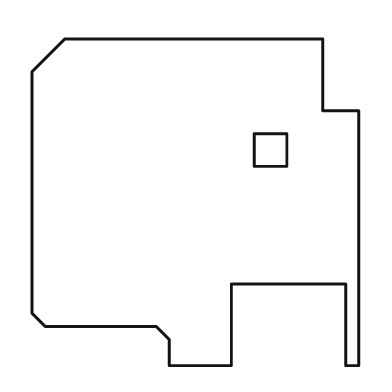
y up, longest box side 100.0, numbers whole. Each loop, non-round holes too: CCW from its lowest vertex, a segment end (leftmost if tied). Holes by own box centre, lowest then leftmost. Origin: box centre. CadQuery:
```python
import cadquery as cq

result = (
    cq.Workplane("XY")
    .moveTo(-8.0, -50.0)
    .lineTo(11.0, -50.0)
    .lineTo(11.0, -25.0)
    .lineTo(46.0, -25.0)
    .lineTo(46.0, -50.0)
    .lineTo(50.0, -50.0)
    .lineTo(50.0, 28.0)
    .lineTo(39.0, 28.0)
    .lineTo(39.0, 50.0)
    .lineTo(-40.0, 50.0)
    .lineTo(-50.0, 40.0)
    .lineTo(-50.0, -34.0)
    .lineTo(-46.0, -38.0)
    .lineTo(-12.0, -38.0)
    .lineTo(-8.0, -42.0)
    .close()
    .moveTo(18.0, 11.0)
    .lineTo(28.0, 11.0)
    .lineTo(28.0, 21.0)
    .lineTo(18.0, 21.0)
    .close()
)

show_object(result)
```